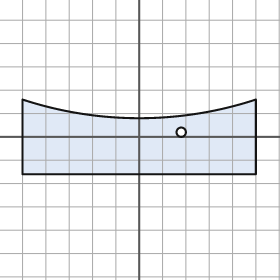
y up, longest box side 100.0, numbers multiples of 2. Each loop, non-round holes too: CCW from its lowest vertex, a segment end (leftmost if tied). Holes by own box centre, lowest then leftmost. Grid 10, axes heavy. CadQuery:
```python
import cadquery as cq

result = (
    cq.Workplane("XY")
    .moveTo(-50.0, -16.0)
    .lineTo(50.0, -16.0)
    .lineTo(50.0, 16.0)
    .threePointArc((0.0, 8.0), (-50.0, 16.0))
    .close()
    .moveTo(18.0, 2.0)
    .circle(2.0)
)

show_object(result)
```